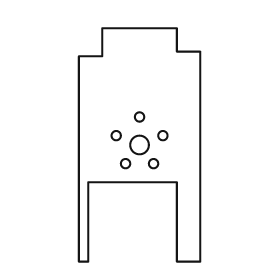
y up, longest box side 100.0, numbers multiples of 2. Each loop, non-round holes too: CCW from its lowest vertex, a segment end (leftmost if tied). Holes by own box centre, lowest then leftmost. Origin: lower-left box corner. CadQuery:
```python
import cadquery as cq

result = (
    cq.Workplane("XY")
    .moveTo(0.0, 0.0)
    .lineTo(4.0, 0.0)
    .lineTo(4.0, 34.0)
    .lineTo(42.0, 34.0)
    .lineTo(42.0, 0.0)
    .lineTo(52.0, 0.0)
    .lineTo(52.0, 90.0)
    .lineTo(42.0, 90.0)
    .lineTo(42.0, 100.0)
    .lineTo(10.0, 100.0)
    .lineTo(10.0, 88.0)
    .lineTo(0.0, 88.0)
    .close()
    .moveTo(20.0, 42.0)
    .circle(2.0)
    .moveTo(32.0, 42.0)
    .circle(2.0)
    .moveTo(26.0, 50.0)
    .circle(4.0)
    .moveTo(16.0, 54.0)
    .circle(2.0)
    .moveTo(36.0, 54.0)
    .circle(2.0)
    .moveTo(26.0, 62.0)
    .circle(2.0)
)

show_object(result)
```